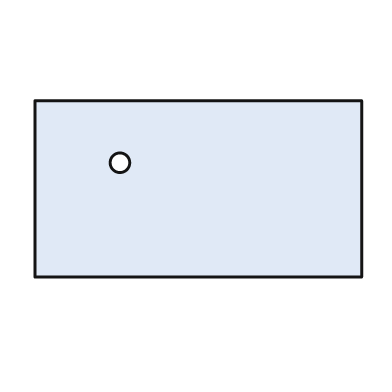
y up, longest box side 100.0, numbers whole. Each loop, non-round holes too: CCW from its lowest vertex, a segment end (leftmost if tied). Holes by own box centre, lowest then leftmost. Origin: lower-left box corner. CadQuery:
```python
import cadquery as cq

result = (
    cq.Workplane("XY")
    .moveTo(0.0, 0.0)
    .lineTo(100.0, 0.0)
    .lineTo(100.0, 54.0)
    .lineTo(0.0, 54.0)
    .close()
    .moveTo(26.0, 35.0)
    .circle(3.0)
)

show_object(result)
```